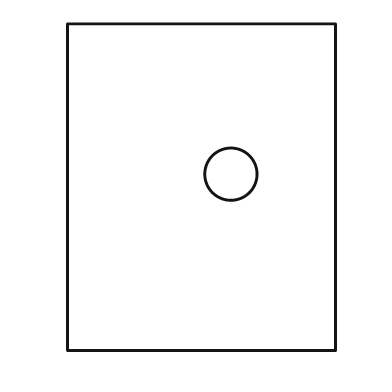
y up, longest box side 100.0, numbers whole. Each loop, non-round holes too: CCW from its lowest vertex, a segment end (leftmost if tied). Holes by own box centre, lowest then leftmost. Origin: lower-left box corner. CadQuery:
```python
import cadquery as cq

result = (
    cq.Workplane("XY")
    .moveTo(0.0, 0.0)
    .lineTo(82.0, 0.0)
    .lineTo(82.0, 100.0)
    .lineTo(0.0, 100.0)
    .close()
    .moveTo(50.0, 54.0)
    .circle(8.0)
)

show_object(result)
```